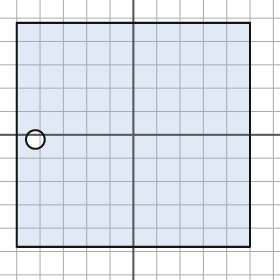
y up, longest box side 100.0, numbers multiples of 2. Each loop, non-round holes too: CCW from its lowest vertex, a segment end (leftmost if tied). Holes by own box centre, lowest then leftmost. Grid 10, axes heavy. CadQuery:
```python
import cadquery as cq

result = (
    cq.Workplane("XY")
    .moveTo(-50.0, -48.0)
    .lineTo(50.0, -48.0)
    .lineTo(50.0, 48.0)
    .lineTo(-50.0, 48.0)
    .close()
    .moveTo(-42.0, -2.0)
    .circle(4.0)
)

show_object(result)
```